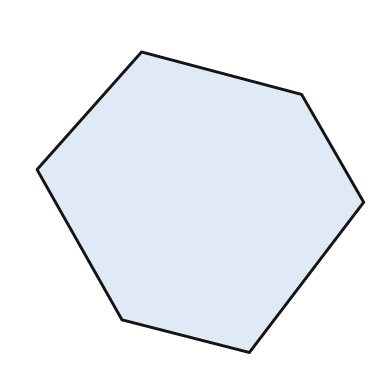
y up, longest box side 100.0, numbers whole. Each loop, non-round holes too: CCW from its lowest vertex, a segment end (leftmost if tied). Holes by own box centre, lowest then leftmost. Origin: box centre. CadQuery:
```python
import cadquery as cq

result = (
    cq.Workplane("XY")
    .moveTo(15.0, -46.0)
    .lineTo(50.0, 0.0)
    .lineTo(31.0, 33.0)
    .lineTo(-18.0, 46.0)
    .lineTo(-50.0, 10.0)
    .lineTo(-24.0, -36.0)
    .close()
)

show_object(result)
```